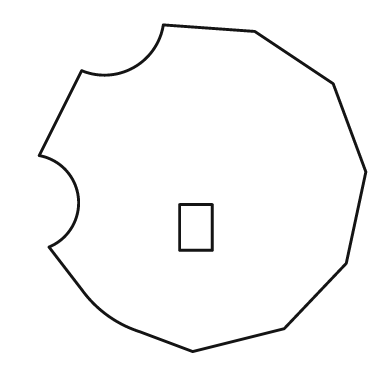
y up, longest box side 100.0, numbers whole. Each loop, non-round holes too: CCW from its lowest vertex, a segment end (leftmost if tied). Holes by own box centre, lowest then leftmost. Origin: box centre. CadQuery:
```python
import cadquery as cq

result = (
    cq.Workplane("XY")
    .moveTo(-3.0, -50.0)
    .lineTo(25.0, -43.0)
    .lineTo(44.0, -23.0)
    .lineTo(50.0, 5.0)
    .lineTo(40.0, 32.0)
    .lineTo(16.0, 48.0)
    .lineTo(-12.0, 50.0)
    .threePointArc((-21.0, 37.0), (-37.0, 36.0))
    .lineTo(-50.0, 10.0)
    .threePointArc((-38.0, -3.0), (-47.0, -18.0))
    .lineTo(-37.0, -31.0)
    .threePointArc((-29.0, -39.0), (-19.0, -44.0))
    .close()
    .moveTo(-7.0, -19.0)
    .lineTo(3.0, -19.0)
    .lineTo(3.0, -5.0)
    .lineTo(-7.0, -5.0)
    .close()
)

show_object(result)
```